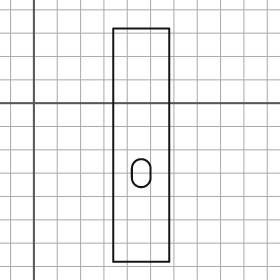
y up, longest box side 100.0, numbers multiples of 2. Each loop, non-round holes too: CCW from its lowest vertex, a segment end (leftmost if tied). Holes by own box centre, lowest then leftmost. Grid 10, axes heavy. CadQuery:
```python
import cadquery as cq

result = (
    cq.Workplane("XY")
    .moveTo(34.0, -68.0)
    .lineTo(58.0, -68.0)
    .lineTo(58.0, 32.0)
    .lineTo(34.0, 32.0)
    .close()
    .moveTo(42.0, -32.0)
    .threePointArc((46.0, -36.0), (50.0, -32.0))
    .lineTo(50.0, -28.0)
    .threePointArc((46.0, -24.0), (42.0, -28.0))
    .close()
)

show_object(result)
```